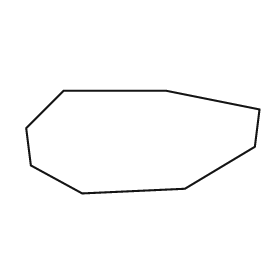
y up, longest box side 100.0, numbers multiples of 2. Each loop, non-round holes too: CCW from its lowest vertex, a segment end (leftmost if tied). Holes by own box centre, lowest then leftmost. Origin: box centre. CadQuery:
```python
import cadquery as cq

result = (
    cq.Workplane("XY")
    .moveTo(-26.0, -22.0)
    .lineTo(18.0, -20.0)
    .lineTo(48.0, -2.0)
    .lineTo(50.0, 14.0)
    .lineTo(10.0, 22.0)
    .lineTo(-34.0, 22.0)
    .lineTo(-50.0, 6.0)
    .lineTo(-48.0, -10.0)
    .close()
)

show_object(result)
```